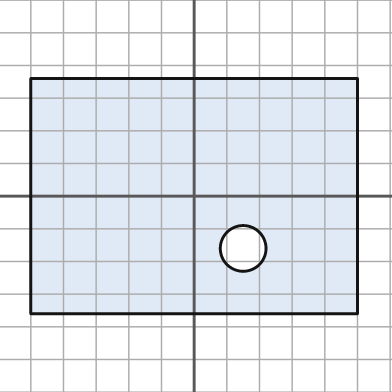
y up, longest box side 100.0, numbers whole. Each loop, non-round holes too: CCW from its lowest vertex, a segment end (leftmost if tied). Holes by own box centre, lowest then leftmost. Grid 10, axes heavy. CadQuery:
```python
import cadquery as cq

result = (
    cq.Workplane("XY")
    .moveTo(-50.0, -36.0)
    .lineTo(50.0, -36.0)
    .lineTo(50.0, 36.0)
    .lineTo(-50.0, 36.0)
    .close()
    .moveTo(15.0, -16.0)
    .circle(7.0)
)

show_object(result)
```